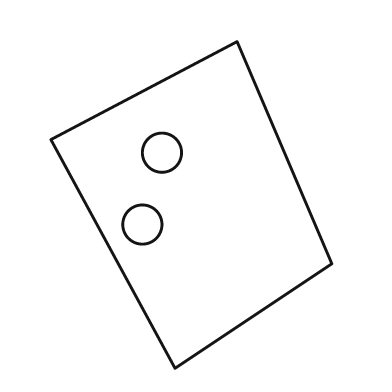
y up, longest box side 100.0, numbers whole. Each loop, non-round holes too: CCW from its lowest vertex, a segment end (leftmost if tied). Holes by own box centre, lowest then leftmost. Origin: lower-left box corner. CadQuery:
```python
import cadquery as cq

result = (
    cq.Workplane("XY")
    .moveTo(38.0, 0.0)
    .lineTo(86.0, 32.0)
    .lineTo(57.0, 100.0)
    .lineTo(0.0, 70.0)
    .close()
    .moveTo(28.0, 44.0)
    .circle(6.0)
    .moveTo(34.0, 66.0)
    .circle(6.0)
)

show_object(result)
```